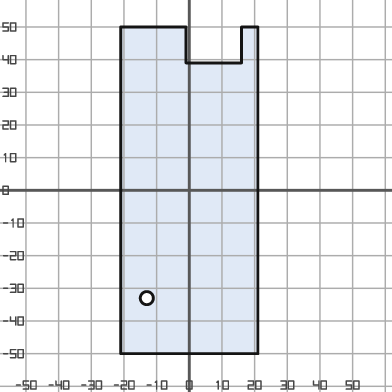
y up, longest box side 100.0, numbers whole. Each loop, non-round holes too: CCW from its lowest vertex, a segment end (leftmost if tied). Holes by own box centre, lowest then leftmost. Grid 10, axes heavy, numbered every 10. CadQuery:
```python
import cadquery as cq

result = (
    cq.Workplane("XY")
    .moveTo(-21.0, -50.0)
    .lineTo(21.0, -50.0)
    .lineTo(21.0, 50.0)
    .lineTo(16.0, 50.0)
    .lineTo(16.0, 39.0)
    .lineTo(-1.0, 39.0)
    .lineTo(-1.0, 50.0)
    .lineTo(-21.0, 50.0)
    .close()
    .moveTo(-13.0, -33.0)
    .circle(2.0)
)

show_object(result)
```